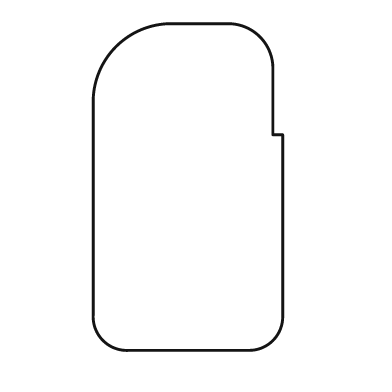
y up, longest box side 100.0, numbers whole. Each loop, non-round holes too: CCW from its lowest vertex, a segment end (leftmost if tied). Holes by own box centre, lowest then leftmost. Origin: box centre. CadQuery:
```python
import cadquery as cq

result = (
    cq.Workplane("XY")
    .moveTo(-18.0, -50.0)
    .lineTo(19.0, -50.0)
    .threePointArc((26.0, -47.0), (29.0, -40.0))
    .lineTo(29.0, 16.0)
    .lineTo(26.0, 16.0)
    .lineTo(26.0, 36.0)
    .threePointArc((22.0, 46.0), (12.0, 50.0))
    .lineTo(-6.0, 50.0)
    .threePointArc((-22.0, 43.0), (-29.0, 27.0))
    .lineTo(-29.0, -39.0)
    .threePointArc((-26.0, -47.0), (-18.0, -50.0))
    .close()
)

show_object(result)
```